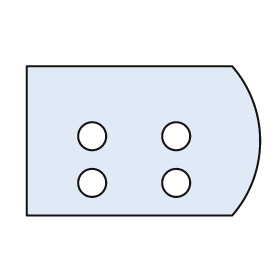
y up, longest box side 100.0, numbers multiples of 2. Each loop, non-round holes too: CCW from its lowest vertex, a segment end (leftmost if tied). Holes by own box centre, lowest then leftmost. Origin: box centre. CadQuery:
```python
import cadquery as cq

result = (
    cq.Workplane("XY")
    .moveTo(-50.0, -32.0)
    .lineTo(38.0, -32.0)
    .threePointArc((50.0, 0.0), (38.0, 32.0))
    .lineTo(-50.0, 32.0)
    .close()
    .moveTo(-22.0, -18.0)
    .circle(6.0)
    .moveTo(14.0, -18.0)
    .circle(6.0)
    .moveTo(-22.0, 2.0)
    .circle(6.0)
    .moveTo(14.0, 2.0)
    .circle(6.0)
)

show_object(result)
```